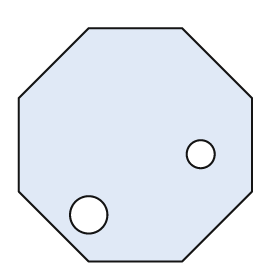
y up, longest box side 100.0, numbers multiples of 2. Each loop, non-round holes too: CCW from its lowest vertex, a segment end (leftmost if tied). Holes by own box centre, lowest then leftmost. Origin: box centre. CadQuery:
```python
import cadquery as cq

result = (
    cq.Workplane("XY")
    .moveTo(-20.0, -50.0)
    .lineTo(20.0, -50.0)
    .lineTo(50.0, -20.0)
    .lineTo(50.0, 20.0)
    .lineTo(20.0, 50.0)
    .lineTo(-20.0, 50.0)
    .lineTo(-50.0, 20.0)
    .lineTo(-50.0, -20.0)
    .close()
    .moveTo(-20.0, -30.0)
    .circle(8.0)
    .moveTo(28.0, -4.0)
    .circle(6.0)
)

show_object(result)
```